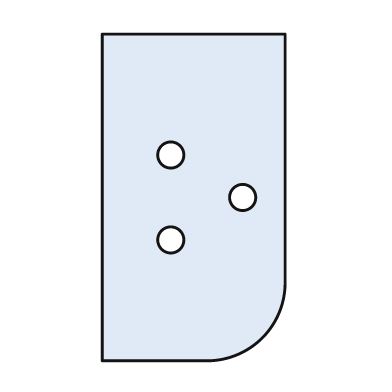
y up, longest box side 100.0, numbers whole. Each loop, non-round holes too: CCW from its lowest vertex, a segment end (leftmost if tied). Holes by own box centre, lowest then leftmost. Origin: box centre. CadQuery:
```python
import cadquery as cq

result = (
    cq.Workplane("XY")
    .moveTo(-28.0, -50.0)
    .lineTo(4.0, -50.0)
    .threePointArc((21.0, -43.0), (28.0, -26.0))
    .lineTo(28.0, 50.0)
    .lineTo(-28.0, 50.0)
    .close()
    .moveTo(-7.0, -13.0)
    .circle(4.0)
    .moveTo(15.0, 0.0)
    .circle(4.0)
    .moveTo(-7.0, 13.0)
    .circle(4.0)
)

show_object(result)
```